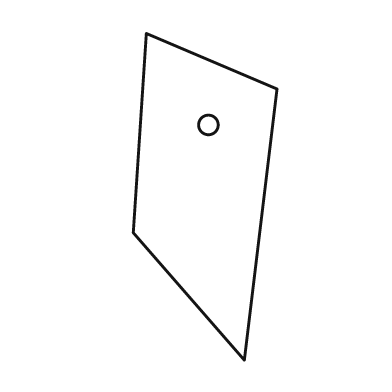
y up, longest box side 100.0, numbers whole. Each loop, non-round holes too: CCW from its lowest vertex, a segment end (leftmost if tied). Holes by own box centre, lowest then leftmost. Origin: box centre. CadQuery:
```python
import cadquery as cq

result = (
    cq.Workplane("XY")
    .moveTo(12.0, -50.0)
    .lineTo(22.0, 33.0)
    .lineTo(-18.0, 50.0)
    .lineTo(-22.0, -11.0)
    .close()
    .moveTo(1.0, 22.0)
    .circle(3.0)
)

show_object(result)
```